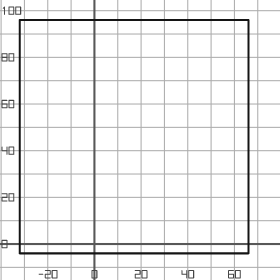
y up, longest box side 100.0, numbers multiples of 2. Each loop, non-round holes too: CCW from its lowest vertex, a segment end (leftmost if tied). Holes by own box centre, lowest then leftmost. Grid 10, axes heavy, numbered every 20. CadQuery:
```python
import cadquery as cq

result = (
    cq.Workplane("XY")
    .moveTo(-32.0, -4.0)
    .lineTo(66.0, -4.0)
    .lineTo(66.0, 96.0)
    .lineTo(-32.0, 96.0)
    .close()
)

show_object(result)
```